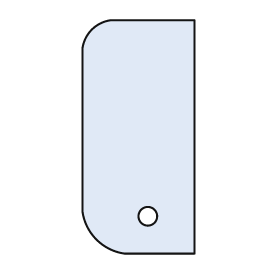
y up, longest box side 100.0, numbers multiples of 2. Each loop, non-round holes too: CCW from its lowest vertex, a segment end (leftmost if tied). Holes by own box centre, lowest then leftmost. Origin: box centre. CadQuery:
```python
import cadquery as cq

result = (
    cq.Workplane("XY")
    .moveTo(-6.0, -50.0)
    .lineTo(24.0, -50.0)
    .lineTo(24.0, 50.0)
    .lineTo(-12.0, 50.0)
    .threePointArc((-20.0, 46.0), (-24.0, 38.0))
    .lineTo(-24.0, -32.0)
    .threePointArc((-18.0, -44.0), (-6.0, -50.0))
    .close()
    .moveTo(4.0, -34.0)
    .circle(4.0)
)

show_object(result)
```